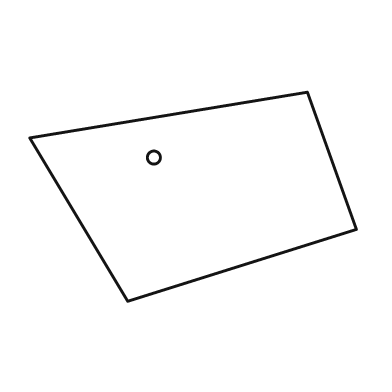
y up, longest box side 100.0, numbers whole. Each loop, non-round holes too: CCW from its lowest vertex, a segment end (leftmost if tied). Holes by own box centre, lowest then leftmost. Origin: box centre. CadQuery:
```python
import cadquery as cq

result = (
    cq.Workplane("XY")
    .moveTo(-20.0, -32.0)
    .lineTo(50.0, -10.0)
    .lineTo(35.0, 32.0)
    .lineTo(-50.0, 18.0)
    .close()
    .moveTo(-12.0, 12.0)
    .circle(2.0)
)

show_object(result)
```